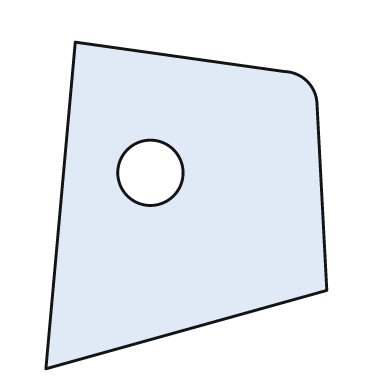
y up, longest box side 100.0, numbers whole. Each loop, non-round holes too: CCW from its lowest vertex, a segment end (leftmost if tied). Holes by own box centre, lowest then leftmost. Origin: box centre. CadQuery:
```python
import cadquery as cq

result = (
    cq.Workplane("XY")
    .moveTo(-43.0, -50.0)
    .lineTo(43.0, -26.0)
    .lineTo(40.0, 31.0)
    .threePointArc((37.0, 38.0), (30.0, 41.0))
    .lineTo(-34.0, 50.0)
    .close()
    .moveTo(-11.0, 10.0)
    .circle(10.0)
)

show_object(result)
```